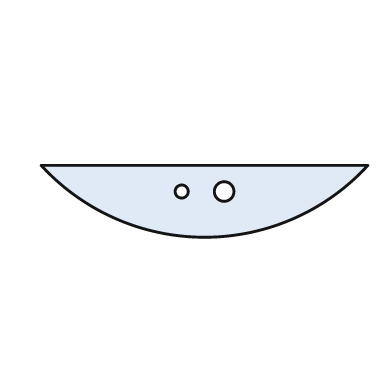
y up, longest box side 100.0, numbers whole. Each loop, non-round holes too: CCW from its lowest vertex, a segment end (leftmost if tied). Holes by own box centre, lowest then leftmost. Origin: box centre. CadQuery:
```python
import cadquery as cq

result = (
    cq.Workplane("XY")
    .moveTo(-50.0, 11.0)
    .threePointArc((0.0, -11.0), (50.0, 11.0))
    .close()
    .moveTo(-7.0, 3.0)
    .circle(2.0)
    .moveTo(6.0, 3.0)
    .circle(3.0)
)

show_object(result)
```